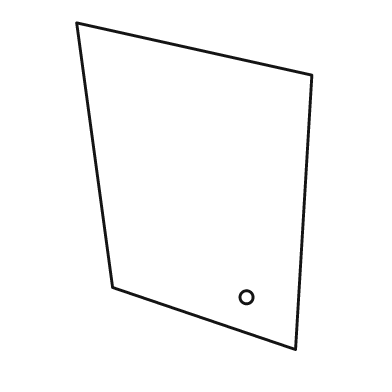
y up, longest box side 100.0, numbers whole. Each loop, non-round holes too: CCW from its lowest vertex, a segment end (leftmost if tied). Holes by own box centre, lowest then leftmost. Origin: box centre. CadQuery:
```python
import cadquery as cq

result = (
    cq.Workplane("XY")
    .moveTo(31.0, -50.0)
    .lineTo(36.0, 34.0)
    .lineTo(-36.0, 50.0)
    .lineTo(-25.0, -31.0)
    .close()
    .moveTo(16.0, -34.0)
    .circle(2.0)
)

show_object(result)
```